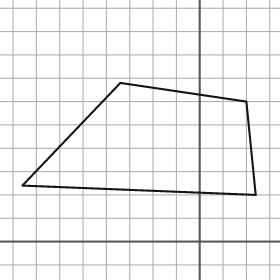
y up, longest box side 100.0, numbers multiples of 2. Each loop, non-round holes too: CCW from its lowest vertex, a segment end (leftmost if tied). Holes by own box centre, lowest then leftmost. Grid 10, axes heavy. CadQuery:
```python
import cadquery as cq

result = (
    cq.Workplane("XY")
    .moveTo(24.0, 20.0)
    .lineTo(20.0, 60.0)
    .lineTo(-34.0, 68.0)
    .lineTo(-76.0, 24.0)
    .close()
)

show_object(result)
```